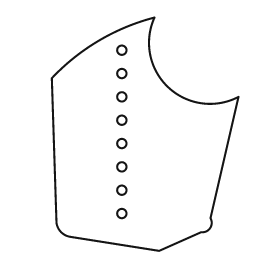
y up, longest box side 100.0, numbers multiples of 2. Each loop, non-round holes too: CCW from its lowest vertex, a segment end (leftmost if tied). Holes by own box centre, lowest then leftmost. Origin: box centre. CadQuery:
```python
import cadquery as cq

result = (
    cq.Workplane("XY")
    .moveTo(6.0, -50.0)
    .lineTo(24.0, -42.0)
    .threePointArc((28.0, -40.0), (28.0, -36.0))
    .lineTo(40.0, 16.0)
    .threePointArc((10.0, 20.0), (4.0, 50.0))
    .threePointArc((-20.0, 40.0), (-40.0, 24.0))
    .lineTo(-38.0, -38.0)
    .threePointArc((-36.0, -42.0), (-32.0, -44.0))
    .close()
    .moveTo(-10.0, -34.0)
    .circle(2.0)
    .moveTo(-10.0, -24.0)
    .circle(2.0)
    .moveTo(-10.0, -14.0)
    .circle(2.0)
    .moveTo(-10.0, -4.0)
    .circle(2.0)
    .moveTo(-10.0, 6.0)
    .circle(2.0)
    .moveTo(-10.0, 16.0)
    .circle(2.0)
    .moveTo(-10.0, 26.0)
    .circle(2.0)
    .moveTo(-10.0, 36.0)
    .circle(2.0)
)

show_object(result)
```